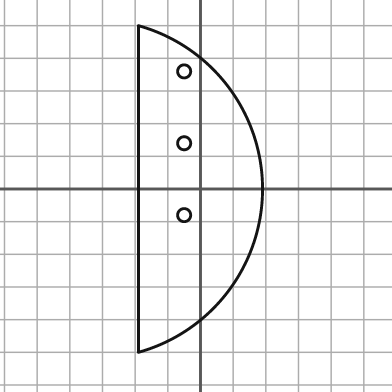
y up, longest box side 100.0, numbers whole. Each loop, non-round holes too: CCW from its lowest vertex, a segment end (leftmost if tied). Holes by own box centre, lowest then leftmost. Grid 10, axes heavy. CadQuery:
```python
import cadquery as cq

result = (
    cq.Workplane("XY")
    .moveTo(-19.0, -50.0)
    .threePointArc((19.0, 0.0), (-19.0, 50.0))
    .close()
    .moveTo(-5.0, -8.0)
    .circle(2.0)
    .moveTo(-5.0, 14.0)
    .circle(2.0)
    .moveTo(-5.0, 36.0)
    .circle(2.0)
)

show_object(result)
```